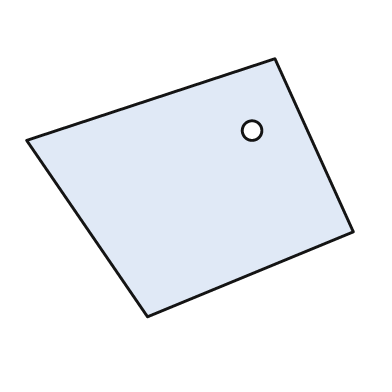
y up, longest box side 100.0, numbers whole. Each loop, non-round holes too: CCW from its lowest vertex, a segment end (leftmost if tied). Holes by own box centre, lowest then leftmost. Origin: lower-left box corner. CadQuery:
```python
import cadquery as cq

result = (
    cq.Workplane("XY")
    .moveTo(37.0, 0.0)
    .lineTo(100.0, 26.0)
    .lineTo(76.0, 79.0)
    .lineTo(0.0, 54.0)
    .close()
    .moveTo(69.0, 57.0)
    .circle(3.0)
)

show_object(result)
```